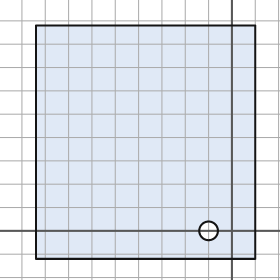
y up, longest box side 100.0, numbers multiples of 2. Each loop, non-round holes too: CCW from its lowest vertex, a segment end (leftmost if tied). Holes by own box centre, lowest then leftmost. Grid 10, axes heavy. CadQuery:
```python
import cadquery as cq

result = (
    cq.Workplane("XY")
    .moveTo(-84.0, -12.0)
    .lineTo(10.0, -12.0)
    .lineTo(10.0, 88.0)
    .lineTo(-84.0, 88.0)
    .close()
    .moveTo(-10.0, 0.0)
    .circle(4.0)
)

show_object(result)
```